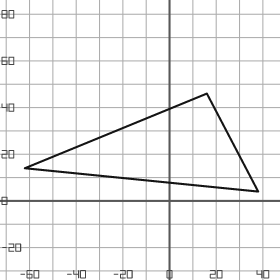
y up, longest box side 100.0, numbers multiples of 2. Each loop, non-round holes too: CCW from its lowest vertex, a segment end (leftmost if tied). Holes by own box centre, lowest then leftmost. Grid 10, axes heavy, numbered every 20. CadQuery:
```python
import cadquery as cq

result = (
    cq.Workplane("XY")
    .moveTo(38.0, 4.0)
    .lineTo(16.0, 46.0)
    .lineTo(-62.0, 14.0)
    .close()
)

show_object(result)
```